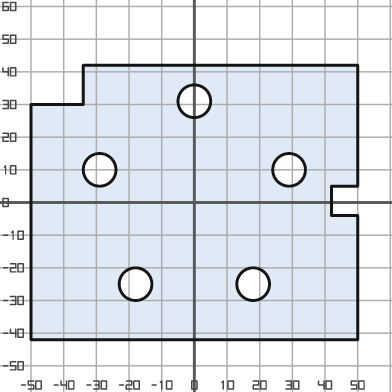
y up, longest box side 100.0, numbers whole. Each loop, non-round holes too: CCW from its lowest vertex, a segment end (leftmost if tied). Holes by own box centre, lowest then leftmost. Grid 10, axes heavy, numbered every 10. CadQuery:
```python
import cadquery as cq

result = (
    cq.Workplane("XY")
    .moveTo(-50.0, -42.0)
    .lineTo(50.0, -42.0)
    .lineTo(50.0, -4.0)
    .lineTo(42.0, -4.0)
    .lineTo(42.0, 5.0)
    .lineTo(50.0, 5.0)
    .lineTo(50.0, 42.0)
    .lineTo(-34.0, 42.0)
    .lineTo(-34.0, 30.0)
    .lineTo(-50.0, 30.0)
    .close()
    .moveTo(-18.0, -25.0)
    .circle(5.0)
    .moveTo(18.0, -25.0)
    .circle(5.0)
    .moveTo(-29.0, 10.0)
    .circle(5.0)
    .moveTo(29.0, 10.0)
    .circle(5.0)
    .moveTo(0.0, 31.0)
    .circle(5.0)
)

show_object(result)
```